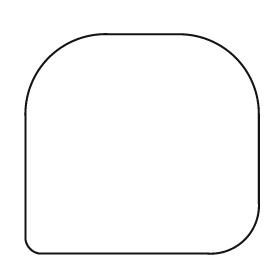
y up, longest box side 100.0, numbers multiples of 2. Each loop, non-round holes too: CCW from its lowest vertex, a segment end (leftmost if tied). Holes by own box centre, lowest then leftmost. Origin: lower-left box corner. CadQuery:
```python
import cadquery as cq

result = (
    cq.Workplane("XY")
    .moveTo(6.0, 0.0)
    .lineTo(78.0, 0.0)
    .threePointArc((94.0, 6.0), (100.0, 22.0))
    .lineTo(100.0, 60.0)
    .threePointArc((90.0, 84.0), (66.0, 94.0))
    .lineTo(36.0, 94.0)
    .threePointArc((10.0, 84.0), (0.0, 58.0))
    .lineTo(0.0, 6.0)
    .threePointArc((2.0, 2.0), (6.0, 0.0))
    .close()
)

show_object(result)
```